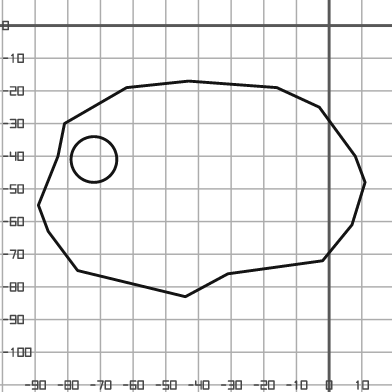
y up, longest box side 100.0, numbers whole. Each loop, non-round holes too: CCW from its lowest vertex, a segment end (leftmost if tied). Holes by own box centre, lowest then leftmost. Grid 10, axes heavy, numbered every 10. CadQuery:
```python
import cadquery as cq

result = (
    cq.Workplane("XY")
    .moveTo(-44.0, -83.0)
    .lineTo(-31.0, -76.0)
    .lineTo(-2.0, -72.0)
    .lineTo(7.0, -61.0)
    .lineTo(11.0, -48.0)
    .lineTo(8.0, -40.0)
    .lineTo(-3.0, -25.0)
    .lineTo(-16.0, -19.0)
    .lineTo(-43.0, -17.0)
    .lineTo(-62.0, -19.0)
    .lineTo(-81.0, -30.0)
    .lineTo(-83.0, -40.0)
    .lineTo(-89.0, -55.0)
    .lineTo(-86.0, -63.0)
    .lineTo(-77.0, -75.0)
    .close()
    .moveTo(-72.0, -41.0)
    .circle(7.0)
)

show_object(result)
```